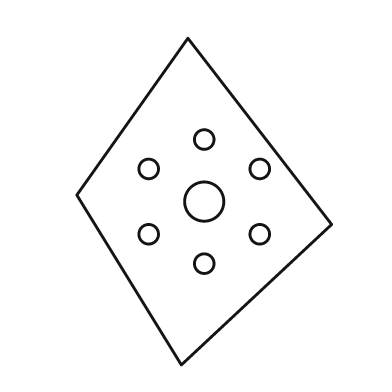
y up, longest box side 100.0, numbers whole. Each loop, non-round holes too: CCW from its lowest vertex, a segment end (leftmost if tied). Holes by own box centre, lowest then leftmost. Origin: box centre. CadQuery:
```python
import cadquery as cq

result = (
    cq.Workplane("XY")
    .moveTo(-7.0, -50.0)
    .lineTo(39.0, -7.0)
    .lineTo(-5.0, 50.0)
    .lineTo(-39.0, 2.0)
    .close()
    .moveTo(0.0, -19.0)
    .circle(3.0)
    .moveTo(-17.0, -10.0)
    .circle(3.0)
    .moveTo(17.0, -10.0)
    .circle(3.0)
    .moveTo(0.0, 0.0)
    .circle(6.0)
    .moveTo(-17.0, 10.0)
    .circle(3.0)
    .moveTo(17.0, 10.0)
    .circle(3.0)
    .moveTo(0.0, 19.0)
    .circle(3.0)
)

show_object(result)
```